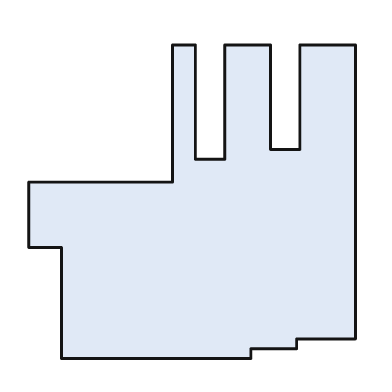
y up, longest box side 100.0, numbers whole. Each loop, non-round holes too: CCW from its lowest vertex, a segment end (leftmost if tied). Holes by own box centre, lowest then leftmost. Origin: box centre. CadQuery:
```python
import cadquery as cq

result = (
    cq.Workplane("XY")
    .moveTo(-40.0, -48.0)
    .lineTo(18.0, -48.0)
    .lineTo(18.0, -45.0)
    .lineTo(32.0, -45.0)
    .lineTo(32.0, -42.0)
    .lineTo(50.0, -42.0)
    .lineTo(50.0, 48.0)
    .lineTo(33.0, 48.0)
    .lineTo(33.0, 16.0)
    .lineTo(24.0, 16.0)
    .lineTo(24.0, 48.0)
    .lineTo(10.0, 48.0)
    .lineTo(10.0, 13.0)
    .lineTo(1.0, 13.0)
    .lineTo(1.0, 48.0)
    .lineTo(-6.0, 48.0)
    .lineTo(-6.0, 6.0)
    .lineTo(-50.0, 6.0)
    .lineTo(-50.0, -14.0)
    .lineTo(-40.0, -14.0)
    .close()
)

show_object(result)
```